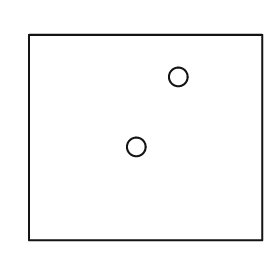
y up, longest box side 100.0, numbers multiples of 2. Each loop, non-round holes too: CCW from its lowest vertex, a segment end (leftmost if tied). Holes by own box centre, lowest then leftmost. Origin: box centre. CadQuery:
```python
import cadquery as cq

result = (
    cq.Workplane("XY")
    .moveTo(-50.0, -44.0)
    .lineTo(50.0, -44.0)
    .lineTo(50.0, 44.0)
    .lineTo(-50.0, 44.0)
    .close()
    .moveTo(-4.0, -4.0)
    .circle(4.0)
    .moveTo(14.0, 26.0)
    .circle(4.0)
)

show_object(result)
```